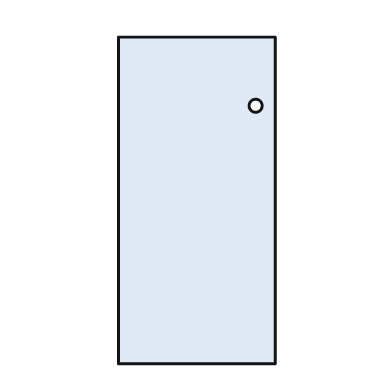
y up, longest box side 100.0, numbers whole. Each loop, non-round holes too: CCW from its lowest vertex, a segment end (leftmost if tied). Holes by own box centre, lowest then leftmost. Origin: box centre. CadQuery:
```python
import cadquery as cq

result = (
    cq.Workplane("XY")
    .moveTo(-24.0, -50.0)
    .lineTo(24.0, -50.0)
    .lineTo(24.0, 50.0)
    .lineTo(-24.0, 50.0)
    .close()
    .moveTo(18.0, 29.0)
    .circle(2.0)
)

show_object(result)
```